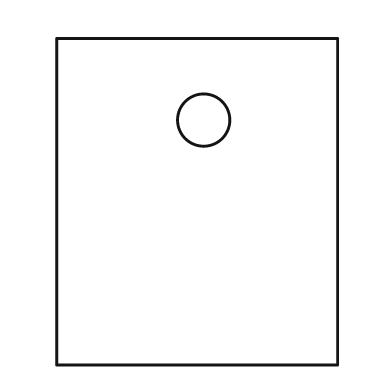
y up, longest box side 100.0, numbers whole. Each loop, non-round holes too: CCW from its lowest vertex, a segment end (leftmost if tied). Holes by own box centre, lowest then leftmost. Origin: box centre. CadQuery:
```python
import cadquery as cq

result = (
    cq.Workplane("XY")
    .moveTo(-43.0, -50.0)
    .lineTo(43.0, -50.0)
    .lineTo(43.0, 50.0)
    .lineTo(-43.0, 50.0)
    .close()
    .moveTo(2.0, 25.0)
    .circle(8.0)
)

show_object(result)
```